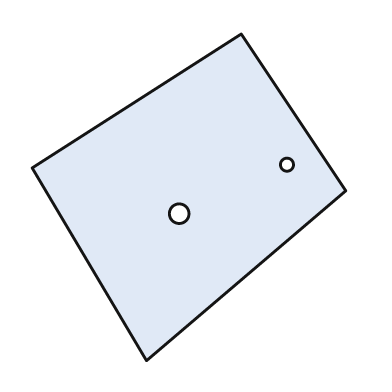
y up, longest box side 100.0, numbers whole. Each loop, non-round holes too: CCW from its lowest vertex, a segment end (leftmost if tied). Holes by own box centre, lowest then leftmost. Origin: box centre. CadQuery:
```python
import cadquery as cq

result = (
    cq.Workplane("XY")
    .moveTo(-13.0, -50.0)
    .lineTo(48.0, 2.0)
    .lineTo(16.0, 50.0)
    .lineTo(-48.0, 9.0)
    .close()
    .moveTo(-3.0, -5.0)
    .circle(3.0)
    .moveTo(30.0, 10.0)
    .circle(2.0)
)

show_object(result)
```